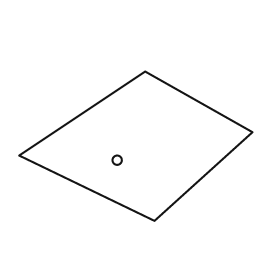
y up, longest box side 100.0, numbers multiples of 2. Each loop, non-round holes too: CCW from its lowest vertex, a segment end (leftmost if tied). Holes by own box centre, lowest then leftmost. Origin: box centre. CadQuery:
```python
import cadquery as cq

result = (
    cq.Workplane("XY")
    .moveTo(8.0, -32.0)
    .lineTo(50.0, 6.0)
    .lineTo(4.0, 32.0)
    .lineTo(-50.0, -4.0)
    .close()
    .moveTo(-8.0, -6.0)
    .circle(2.0)
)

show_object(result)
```